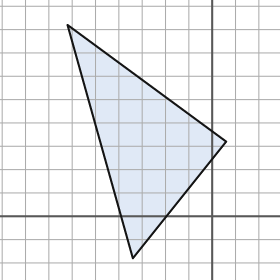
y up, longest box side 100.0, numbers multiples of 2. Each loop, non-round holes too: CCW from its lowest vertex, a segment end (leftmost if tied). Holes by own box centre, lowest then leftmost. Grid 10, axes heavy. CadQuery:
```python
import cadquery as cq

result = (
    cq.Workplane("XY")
    .moveTo(-34.0, -18.0)
    .lineTo(6.0, 32.0)
    .lineTo(-62.0, 82.0)
    .close()
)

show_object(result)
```